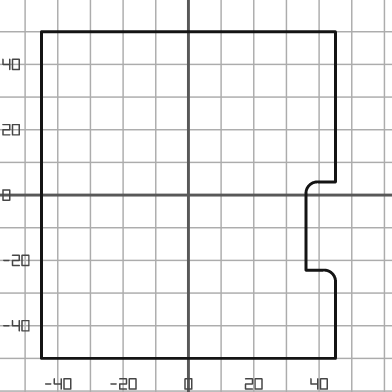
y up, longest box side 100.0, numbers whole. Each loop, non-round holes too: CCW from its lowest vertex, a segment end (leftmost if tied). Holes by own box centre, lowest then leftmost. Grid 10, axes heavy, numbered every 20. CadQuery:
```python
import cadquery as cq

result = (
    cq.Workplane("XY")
    .moveTo(-45.0, -50.0)
    .lineTo(45.0, -50.0)
    .lineTo(45.0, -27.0)
    .threePointArc((44.0, -24.0), (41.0, -23.0))
    .lineTo(36.0, -23.0)
    .lineTo(36.0, 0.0)
    .threePointArc((37.0, 3.0), (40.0, 4.0))
    .lineTo(45.0, 4.0)
    .lineTo(45.0, 50.0)
    .lineTo(-45.0, 50.0)
    .close()
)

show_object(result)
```